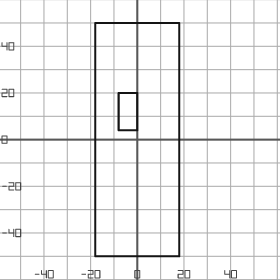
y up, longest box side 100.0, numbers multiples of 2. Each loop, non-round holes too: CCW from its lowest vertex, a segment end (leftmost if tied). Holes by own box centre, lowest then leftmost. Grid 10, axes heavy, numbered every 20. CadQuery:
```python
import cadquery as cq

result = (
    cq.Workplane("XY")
    .moveTo(-18.0, -50.0)
    .lineTo(18.0, -50.0)
    .lineTo(18.0, 50.0)
    .lineTo(-18.0, 50.0)
    .close()
    .moveTo(-8.0, 4.0)
    .lineTo(0.0, 4.0)
    .lineTo(0.0, 20.0)
    .lineTo(-8.0, 20.0)
    .close()
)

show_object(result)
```